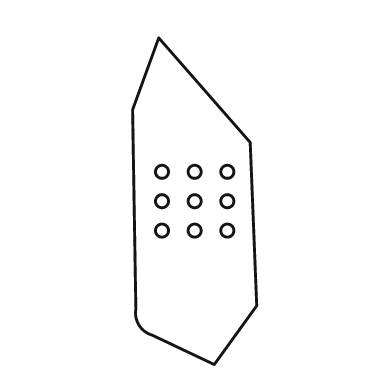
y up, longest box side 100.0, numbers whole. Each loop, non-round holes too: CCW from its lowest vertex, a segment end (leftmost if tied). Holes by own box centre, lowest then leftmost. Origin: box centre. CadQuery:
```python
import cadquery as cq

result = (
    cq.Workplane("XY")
    .moveTo(6.0, -50.0)
    .lineTo(19.0, -32.0)
    .lineTo(17.0, 18.0)
    .lineTo(-11.0, 50.0)
    .lineTo(-19.0, 28.0)
    .lineTo(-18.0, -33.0)
    .threePointArc((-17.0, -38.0), (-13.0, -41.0))
    .close()
    .moveTo(-10.0, -9.0)
    .circle(2.0)
    .moveTo(0.0, -9.0)
    .circle(2.0)
    .moveTo(10.0, -9.0)
    .circle(2.0)
    .moveTo(-10.0, 0.0)
    .circle(2.0)
    .moveTo(0.0, 0.0)
    .circle(2.0)
    .moveTo(10.0, 0.0)
    .circle(2.0)
    .moveTo(-10.0, 9.0)
    .circle(2.0)
    .moveTo(0.0, 9.0)
    .circle(2.0)
    .moveTo(10.0, 9.0)
    .circle(2.0)
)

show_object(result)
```